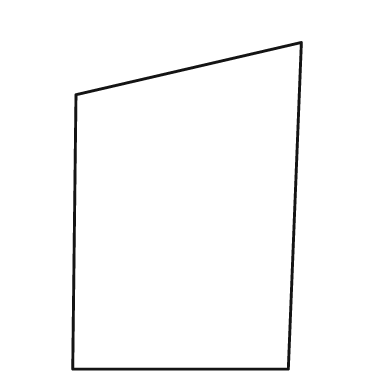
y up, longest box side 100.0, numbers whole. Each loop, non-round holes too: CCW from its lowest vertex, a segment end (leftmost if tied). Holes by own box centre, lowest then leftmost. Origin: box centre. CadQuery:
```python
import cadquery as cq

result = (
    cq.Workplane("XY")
    .moveTo(-35.0, -50.0)
    .lineTo(31.0, -50.0)
    .lineTo(35.0, 50.0)
    .lineTo(-34.0, 34.0)
    .close()
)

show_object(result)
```